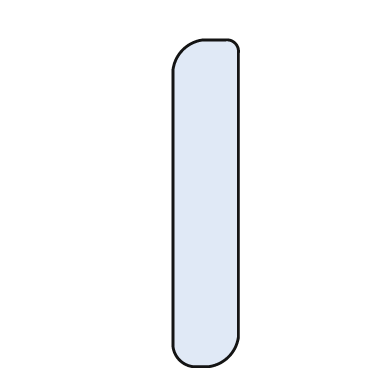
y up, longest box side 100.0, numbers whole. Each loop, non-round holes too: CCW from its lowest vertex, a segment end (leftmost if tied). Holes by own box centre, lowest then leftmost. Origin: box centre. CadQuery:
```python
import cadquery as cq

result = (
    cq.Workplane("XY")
    .moveTo(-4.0, -50.0)
    .lineTo(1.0, -50.0)
    .threePointArc((7.0, -47.0), (10.0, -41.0))
    .lineTo(10.0, 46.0)
    .threePointArc((9.0, 49.0), (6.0, 50.0))
    .lineTo(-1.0, 50.0)
    .threePointArc((-7.0, 47.0), (-10.0, 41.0))
    .lineTo(-10.0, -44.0)
    .threePointArc((-8.0, -48.0), (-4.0, -50.0))
    .close()
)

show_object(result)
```